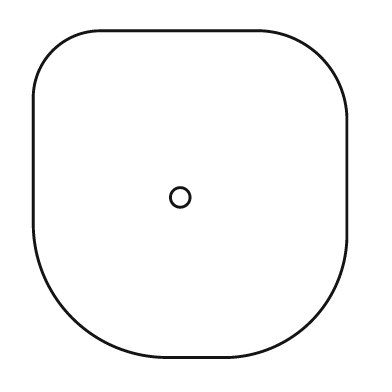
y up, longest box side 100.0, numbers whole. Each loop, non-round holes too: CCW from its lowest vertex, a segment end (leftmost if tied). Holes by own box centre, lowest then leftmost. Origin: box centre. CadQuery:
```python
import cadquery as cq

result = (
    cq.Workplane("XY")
    .moveTo(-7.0, -50.0)
    .lineTo(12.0, -50.0)
    .threePointArc((37.0, -39.0), (48.0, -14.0))
    .lineTo(48.0, 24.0)
    .threePointArc((40.0, 42.0), (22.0, 50.0))
    .lineTo(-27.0, 50.0)
    .threePointArc((-42.0, 44.0), (-48.0, 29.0))
    .lineTo(-48.0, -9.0)
    .threePointArc((-36.0, -38.0), (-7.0, -50.0))
    .close()
    .moveTo(-3.0, -1.0)
    .circle(3.0)
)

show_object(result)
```